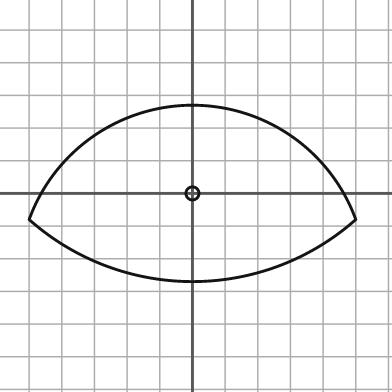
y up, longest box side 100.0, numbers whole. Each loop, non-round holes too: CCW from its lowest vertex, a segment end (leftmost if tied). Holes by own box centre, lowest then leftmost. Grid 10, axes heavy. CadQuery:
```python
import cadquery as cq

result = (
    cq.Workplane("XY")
    .moveTo(-50.0, -8.0)
    .threePointArc((0.0, -27.0), (50.0, -8.0))
    .threePointArc((0.0, 27.0), (-50.0, -8.0))
    .close()
    .moveTo(0.0, 0.0)
    .circle(2.0)
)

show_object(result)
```